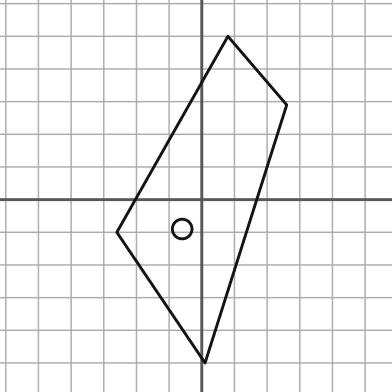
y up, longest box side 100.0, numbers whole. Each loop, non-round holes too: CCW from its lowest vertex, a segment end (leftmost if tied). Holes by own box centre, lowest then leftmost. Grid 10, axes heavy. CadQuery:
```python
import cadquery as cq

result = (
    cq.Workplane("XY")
    .moveTo(1.0, -50.0)
    .lineTo(26.0, 29.0)
    .lineTo(8.0, 50.0)
    .lineTo(-26.0, -10.0)
    .close()
    .moveTo(-6.0, -9.0)
    .circle(3.0)
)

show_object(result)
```